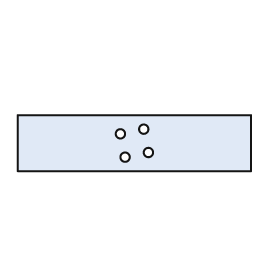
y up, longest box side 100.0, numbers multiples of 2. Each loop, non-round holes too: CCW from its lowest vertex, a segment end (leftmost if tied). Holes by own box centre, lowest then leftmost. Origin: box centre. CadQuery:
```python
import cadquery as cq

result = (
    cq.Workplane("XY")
    .moveTo(-50.0, -12.0)
    .lineTo(50.0, -12.0)
    .lineTo(50.0, 12.0)
    .lineTo(-50.0, 12.0)
    .close()
    .moveTo(-4.0, -6.0)
    .circle(2.0)
    .moveTo(6.0, -4.0)
    .circle(2.0)
    .moveTo(-6.0, 4.0)
    .circle(2.0)
    .moveTo(4.0, 6.0)
    .circle(2.0)
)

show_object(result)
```